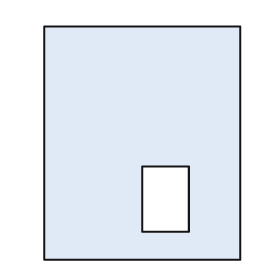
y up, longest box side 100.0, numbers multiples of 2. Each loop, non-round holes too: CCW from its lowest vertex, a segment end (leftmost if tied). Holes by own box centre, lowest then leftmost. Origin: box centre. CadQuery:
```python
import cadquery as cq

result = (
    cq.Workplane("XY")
    .moveTo(-42.0, -50.0)
    .lineTo(42.0, -50.0)
    .lineTo(42.0, 50.0)
    .lineTo(-42.0, 50.0)
    .close()
    .moveTo(0.0, -38.0)
    .lineTo(20.0, -38.0)
    .lineTo(20.0, -10.0)
    .lineTo(0.0, -10.0)
    .close()
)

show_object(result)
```